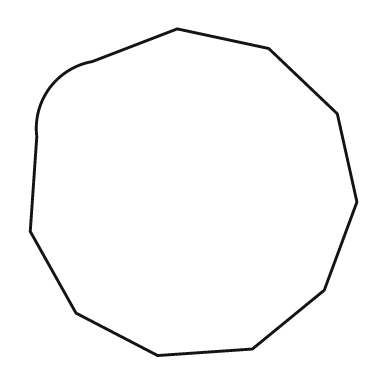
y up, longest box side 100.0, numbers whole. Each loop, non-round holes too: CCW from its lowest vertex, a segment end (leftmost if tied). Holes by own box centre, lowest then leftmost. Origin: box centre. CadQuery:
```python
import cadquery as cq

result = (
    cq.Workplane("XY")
    .moveTo(-11.0, -50.0)
    .lineTo(18.0, -48.0)
    .lineTo(40.0, -30.0)
    .lineTo(50.0, -3.0)
    .lineTo(44.0, 24.0)
    .lineTo(23.0, 44.0)
    .lineTo(-5.0, 50.0)
    .lineTo(-31.0, 40.0)
    .threePointArc((-44.0, 32.0), (-48.0, 17.0))
    .lineTo(-50.0, -12.0)
    .lineTo(-36.0, -37.0)
    .close()
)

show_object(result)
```